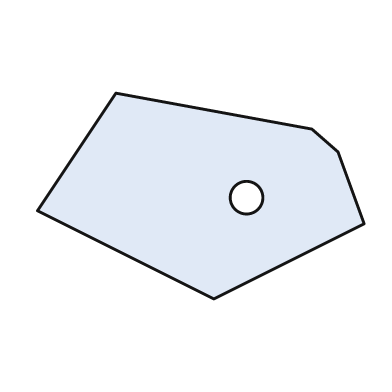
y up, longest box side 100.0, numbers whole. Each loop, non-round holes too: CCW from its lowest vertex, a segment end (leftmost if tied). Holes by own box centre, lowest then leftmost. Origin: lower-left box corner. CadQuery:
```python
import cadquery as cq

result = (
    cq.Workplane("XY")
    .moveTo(54.0, 0.0)
    .lineTo(100.0, 23.0)
    .lineTo(92.0, 45.0)
    .lineTo(84.0, 52.0)
    .lineTo(24.0, 63.0)
    .lineTo(0.0, 27.0)
    .close()
    .moveTo(64.0, 31.0)
    .circle(5.0)
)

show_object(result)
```